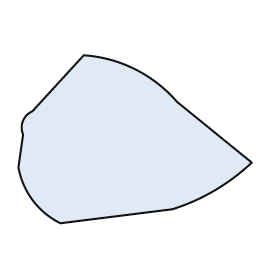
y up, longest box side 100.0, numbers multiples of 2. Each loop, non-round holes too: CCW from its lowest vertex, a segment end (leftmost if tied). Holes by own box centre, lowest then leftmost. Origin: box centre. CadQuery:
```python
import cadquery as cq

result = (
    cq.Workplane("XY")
    .moveTo(-32.0, -36.0)
    .lineTo(16.0, -30.0)
    .threePointArc((34.0, -22.0), (50.0, -10.0))
    .lineTo(18.0, 16.0)
    .threePointArc((0.0, 30.0), (-22.0, 36.0))
    .lineTo(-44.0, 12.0)
    .threePointArc((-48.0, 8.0), (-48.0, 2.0))
    .lineTo(-50.0, -12.0)
    .threePointArc((-44.0, -26.0), (-32.0, -36.0))
    .close()
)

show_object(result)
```